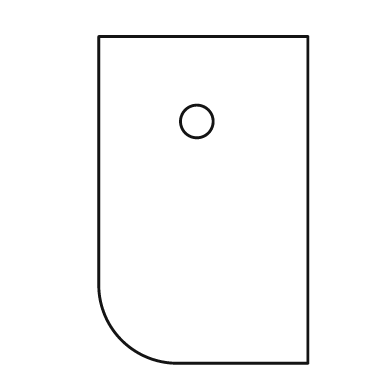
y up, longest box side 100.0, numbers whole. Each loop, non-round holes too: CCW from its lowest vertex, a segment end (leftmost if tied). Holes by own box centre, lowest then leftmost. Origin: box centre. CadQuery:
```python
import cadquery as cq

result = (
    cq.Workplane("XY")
    .moveTo(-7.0, -50.0)
    .lineTo(32.0, -50.0)
    .lineTo(32.0, 50.0)
    .lineTo(-32.0, 50.0)
    .lineTo(-32.0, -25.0)
    .threePointArc((-25.0, -43.0), (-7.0, -50.0))
    .close()
    .moveTo(-2.0, 24.0)
    .circle(5.0)
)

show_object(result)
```